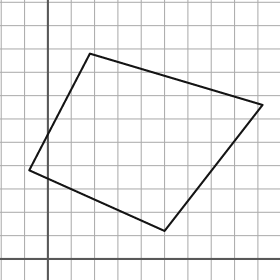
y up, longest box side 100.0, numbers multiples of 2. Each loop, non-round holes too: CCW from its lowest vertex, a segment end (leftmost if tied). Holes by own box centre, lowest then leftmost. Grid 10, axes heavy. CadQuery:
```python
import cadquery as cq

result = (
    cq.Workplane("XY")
    .moveTo(50.0, 12.0)
    .lineTo(92.0, 66.0)
    .lineTo(18.0, 88.0)
    .lineTo(-8.0, 38.0)
    .close()
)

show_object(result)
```